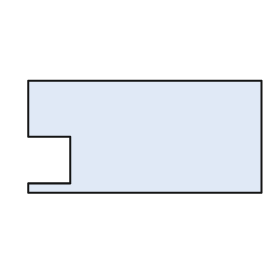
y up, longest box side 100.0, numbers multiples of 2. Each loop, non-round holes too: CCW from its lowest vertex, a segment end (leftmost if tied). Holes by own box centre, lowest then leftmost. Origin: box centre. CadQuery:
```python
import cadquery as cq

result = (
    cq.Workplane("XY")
    .moveTo(-50.0, -24.0)
    .lineTo(50.0, -24.0)
    .lineTo(50.0, 24.0)
    .lineTo(-50.0, 24.0)
    .lineTo(-50.0, 0.0)
    .lineTo(-32.0, 0.0)
    .lineTo(-32.0, -20.0)
    .lineTo(-50.0, -20.0)
    .close()
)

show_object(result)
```